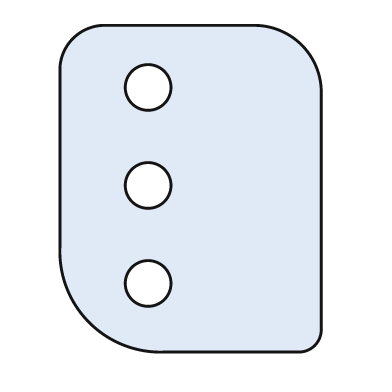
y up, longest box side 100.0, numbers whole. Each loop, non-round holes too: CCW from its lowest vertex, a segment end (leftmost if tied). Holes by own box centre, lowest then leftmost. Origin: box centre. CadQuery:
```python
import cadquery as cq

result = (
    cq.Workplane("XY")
    .moveTo(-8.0, -50.0)
    .lineTo(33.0, -50.0)
    .threePointArc((38.0, -48.0), (40.0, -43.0))
    .lineTo(40.0, 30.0)
    .threePointArc((34.0, 44.0), (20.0, 50.0))
    .lineTo(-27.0, 50.0)
    .threePointArc((-36.0, 46.0), (-40.0, 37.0))
    .lineTo(-40.0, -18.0)
    .threePointArc((-31.0, -41.0), (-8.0, -50.0))
    .close()
    .moveTo(-13.0, -29.0)
    .circle(7.0)
    .moveTo(-13.0, 1.0)
    .circle(7.0)
    .moveTo(-13.0, 31.0)
    .circle(7.0)
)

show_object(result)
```